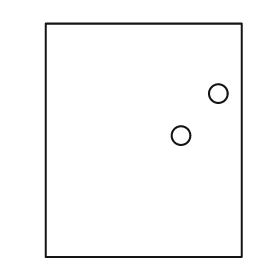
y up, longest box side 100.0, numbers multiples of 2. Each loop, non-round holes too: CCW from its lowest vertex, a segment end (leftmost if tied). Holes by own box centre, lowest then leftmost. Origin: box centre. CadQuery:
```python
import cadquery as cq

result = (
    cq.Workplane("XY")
    .moveTo(-42.0, -50.0)
    .lineTo(42.0, -50.0)
    .lineTo(42.0, 50.0)
    .lineTo(-42.0, 50.0)
    .close()
    .moveTo(16.0, 2.0)
    .circle(4.0)
    .moveTo(32.0, 20.0)
    .circle(4.0)
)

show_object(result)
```